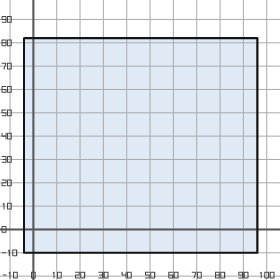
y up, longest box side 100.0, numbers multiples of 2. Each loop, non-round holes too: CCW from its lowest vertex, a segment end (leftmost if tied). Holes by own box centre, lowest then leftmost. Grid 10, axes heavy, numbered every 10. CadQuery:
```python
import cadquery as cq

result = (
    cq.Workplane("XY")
    .moveTo(-4.0, -10.0)
    .lineTo(96.0, -10.0)
    .lineTo(96.0, 82.0)
    .lineTo(-4.0, 82.0)
    .close()
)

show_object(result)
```